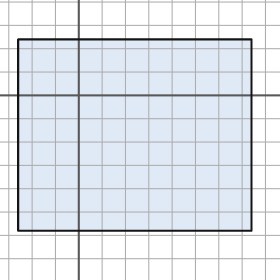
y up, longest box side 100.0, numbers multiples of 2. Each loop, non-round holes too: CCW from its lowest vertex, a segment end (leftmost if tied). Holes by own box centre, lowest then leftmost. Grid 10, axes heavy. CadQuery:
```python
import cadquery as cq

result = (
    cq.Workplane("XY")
    .moveTo(-26.0, -58.0)
    .lineTo(74.0, -58.0)
    .lineTo(74.0, 24.0)
    .lineTo(-26.0, 24.0)
    .close()
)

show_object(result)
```